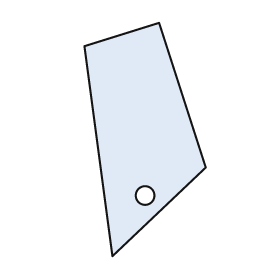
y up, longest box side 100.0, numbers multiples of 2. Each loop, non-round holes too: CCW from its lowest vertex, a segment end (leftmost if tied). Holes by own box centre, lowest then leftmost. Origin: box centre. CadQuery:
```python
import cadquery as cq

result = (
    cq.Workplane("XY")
    .moveTo(-14.0, -50.0)
    .lineTo(26.0, -12.0)
    .lineTo(6.0, 50.0)
    .lineTo(-26.0, 40.0)
    .close()
    .moveTo(0.0, -24.0)
    .circle(4.0)
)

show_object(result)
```